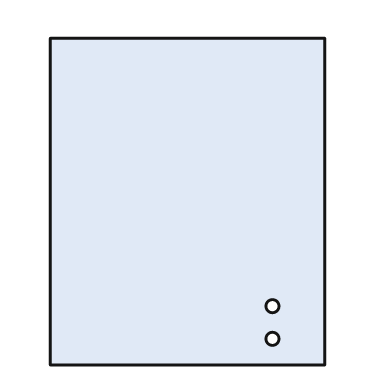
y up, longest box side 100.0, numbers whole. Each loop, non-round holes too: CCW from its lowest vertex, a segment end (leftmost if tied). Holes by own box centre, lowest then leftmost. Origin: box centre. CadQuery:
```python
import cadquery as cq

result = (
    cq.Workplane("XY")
    .moveTo(-42.0, -50.0)
    .lineTo(42.0, -50.0)
    .lineTo(42.0, 50.0)
    .lineTo(-42.0, 50.0)
    .close()
    .moveTo(26.0, -42.0)
    .circle(2.0)
    .moveTo(26.0, -32.0)
    .circle(2.0)
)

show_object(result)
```